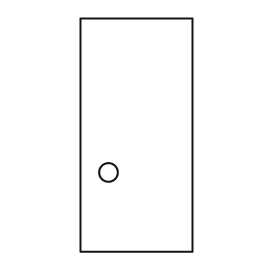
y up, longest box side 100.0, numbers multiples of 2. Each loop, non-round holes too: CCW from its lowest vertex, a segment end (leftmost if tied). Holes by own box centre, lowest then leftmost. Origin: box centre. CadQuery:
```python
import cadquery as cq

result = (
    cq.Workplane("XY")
    .moveTo(-24.0, -50.0)
    .lineTo(24.0, -50.0)
    .lineTo(24.0, 50.0)
    .lineTo(-24.0, 50.0)
    .close()
    .moveTo(-12.0, -16.0)
    .circle(4.0)
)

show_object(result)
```